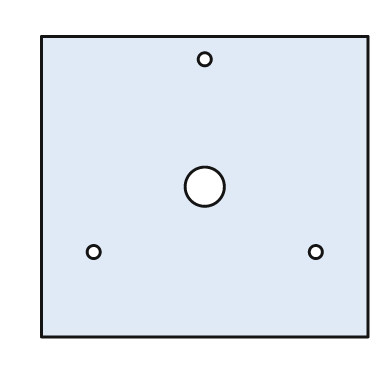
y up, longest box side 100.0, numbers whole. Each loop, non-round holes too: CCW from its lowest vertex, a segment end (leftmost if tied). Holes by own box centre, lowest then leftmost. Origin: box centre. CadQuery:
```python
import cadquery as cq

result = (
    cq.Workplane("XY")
    .moveTo(-50.0, -46.0)
    .lineTo(50.0, -46.0)
    .lineTo(50.0, 46.0)
    .lineTo(-50.0, 46.0)
    .close()
    .moveTo(-34.0, -20.0)
    .circle(2.0)
    .moveTo(34.0, -20.0)
    .circle(2.0)
    .moveTo(0.0, 0.0)
    .circle(6.0)
    .moveTo(0.0, 39.0)
    .circle(2.0)
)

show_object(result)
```